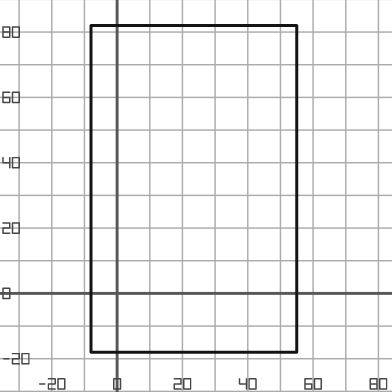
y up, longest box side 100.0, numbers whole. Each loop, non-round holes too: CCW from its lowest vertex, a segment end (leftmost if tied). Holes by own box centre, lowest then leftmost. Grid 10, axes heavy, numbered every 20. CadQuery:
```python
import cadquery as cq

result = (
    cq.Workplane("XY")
    .moveTo(-8.0, -18.0)
    .lineTo(55.0, -18.0)
    .lineTo(55.0, 82.0)
    .lineTo(-8.0, 82.0)
    .close()
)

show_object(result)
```